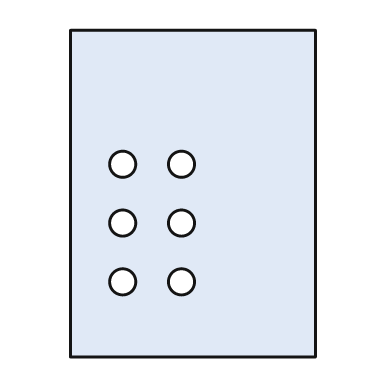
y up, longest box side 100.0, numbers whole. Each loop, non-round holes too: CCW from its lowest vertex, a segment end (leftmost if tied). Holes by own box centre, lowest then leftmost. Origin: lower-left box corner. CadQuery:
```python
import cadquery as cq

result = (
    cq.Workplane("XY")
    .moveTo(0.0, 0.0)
    .lineTo(75.0, 0.0)
    .lineTo(75.0, 100.0)
    .lineTo(0.0, 100.0)
    .close()
    .moveTo(16.0, 23.0)
    .circle(4.0)
    .moveTo(34.0, 23.0)
    .circle(4.0)
    .moveTo(16.0, 41.0)
    .circle(4.0)
    .moveTo(34.0, 41.0)
    .circle(4.0)
    .moveTo(16.0, 59.0)
    .circle(4.0)
    .moveTo(34.0, 59.0)
    .circle(4.0)
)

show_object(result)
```